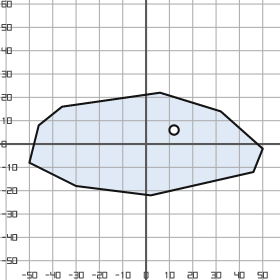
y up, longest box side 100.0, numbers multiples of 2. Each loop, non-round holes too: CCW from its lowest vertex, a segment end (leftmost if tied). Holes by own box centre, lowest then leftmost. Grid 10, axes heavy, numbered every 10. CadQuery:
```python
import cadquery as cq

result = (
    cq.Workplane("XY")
    .moveTo(2.0, -22.0)
    .lineTo(46.0, -12.0)
    .lineTo(50.0, -2.0)
    .lineTo(32.0, 14.0)
    .lineTo(6.0, 22.0)
    .lineTo(-36.0, 16.0)
    .lineTo(-46.0, 8.0)
    .lineTo(-50.0, -8.0)
    .lineTo(-30.0, -18.0)
    .close()
    .moveTo(12.0, 6.0)
    .circle(2.0)
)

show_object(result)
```